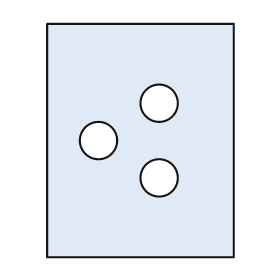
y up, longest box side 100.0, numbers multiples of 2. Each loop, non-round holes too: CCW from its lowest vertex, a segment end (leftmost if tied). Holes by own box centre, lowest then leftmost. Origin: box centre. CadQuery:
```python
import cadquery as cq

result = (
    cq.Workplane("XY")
    .moveTo(-40.0, -50.0)
    .lineTo(40.0, -50.0)
    .lineTo(40.0, 50.0)
    .lineTo(-40.0, 50.0)
    .close()
    .moveTo(8.0, -16.0)
    .circle(8.0)
    .moveTo(-18.0, 0.0)
    .circle(8.0)
    .moveTo(8.0, 16.0)
    .circle(8.0)
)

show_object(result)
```